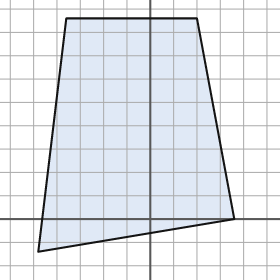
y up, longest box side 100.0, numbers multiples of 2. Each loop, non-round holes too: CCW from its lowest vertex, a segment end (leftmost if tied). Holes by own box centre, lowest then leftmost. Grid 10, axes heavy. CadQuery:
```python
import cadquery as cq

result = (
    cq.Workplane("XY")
    .moveTo(-48.0, -14.0)
    .lineTo(36.0, 0.0)
    .lineTo(20.0, 86.0)
    .lineTo(-36.0, 86.0)
    .close()
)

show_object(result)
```